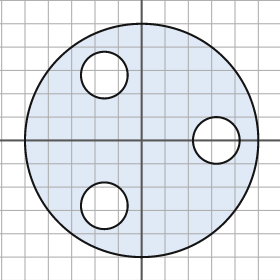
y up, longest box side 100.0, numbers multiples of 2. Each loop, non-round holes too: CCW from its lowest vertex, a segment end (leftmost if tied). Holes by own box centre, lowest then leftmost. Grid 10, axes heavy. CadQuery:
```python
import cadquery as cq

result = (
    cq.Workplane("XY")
    .moveTo(0.0, 0.0)
    .circle(50.0)
    .moveTo(-16.0, -28.0)
    .circle(10.0)
    .moveTo(32.0, 0.0)
    .circle(10.0)
    .moveTo(-16.0, 28.0)
    .circle(10.0)
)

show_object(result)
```